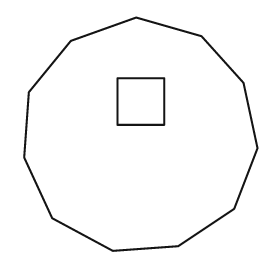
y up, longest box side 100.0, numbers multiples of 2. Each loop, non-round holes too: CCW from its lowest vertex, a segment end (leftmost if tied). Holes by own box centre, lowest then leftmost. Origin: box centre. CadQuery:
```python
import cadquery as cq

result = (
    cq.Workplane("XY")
    .moveTo(-12.0, -50.0)
    .lineTo(16.0, -48.0)
    .lineTo(40.0, -32.0)
    .lineTo(50.0, -6.0)
    .lineTo(44.0, 22.0)
    .lineTo(26.0, 42.0)
    .lineTo(-2.0, 50.0)
    .lineTo(-30.0, 40.0)
    .lineTo(-48.0, 18.0)
    .lineTo(-50.0, -10.0)
    .lineTo(-38.0, -36.0)
    .close()
    .moveTo(-10.0, 4.0)
    .lineTo(10.0, 4.0)
    .lineTo(10.0, 24.0)
    .lineTo(-10.0, 24.0)
    .close()
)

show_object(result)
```